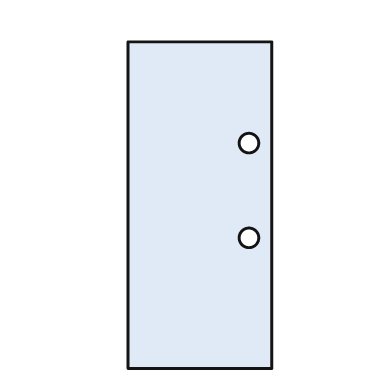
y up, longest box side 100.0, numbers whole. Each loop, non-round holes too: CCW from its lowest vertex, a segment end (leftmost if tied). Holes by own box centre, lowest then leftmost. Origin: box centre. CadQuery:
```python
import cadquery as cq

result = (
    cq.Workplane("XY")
    .moveTo(-22.0, -50.0)
    .lineTo(22.0, -50.0)
    .lineTo(22.0, 50.0)
    .lineTo(-22.0, 50.0)
    .close()
    .moveTo(15.0, -10.0)
    .circle(3.0)
    .moveTo(15.0, 19.0)
    .circle(3.0)
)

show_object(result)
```